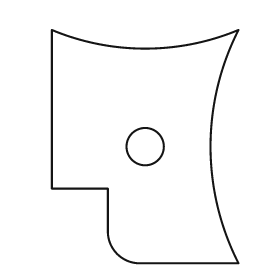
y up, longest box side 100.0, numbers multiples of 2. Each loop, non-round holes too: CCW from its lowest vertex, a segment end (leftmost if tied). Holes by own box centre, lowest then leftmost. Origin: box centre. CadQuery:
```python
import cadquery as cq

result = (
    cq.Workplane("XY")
    .moveTo(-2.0, -50.0)
    .lineTo(40.0, -50.0)
    .threePointArc((28.0, 0.0), (40.0, 50.0))
    .threePointArc((0.0, 42.0), (-40.0, 50.0))
    .lineTo(-40.0, -18.0)
    .lineTo(-16.0, -18.0)
    .lineTo(-16.0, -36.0)
    .threePointArc((-12.0, -46.0), (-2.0, -50.0))
    .close()
    .moveTo(0.0, 0.0)
    .circle(8.0)
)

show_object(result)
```